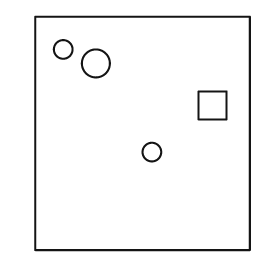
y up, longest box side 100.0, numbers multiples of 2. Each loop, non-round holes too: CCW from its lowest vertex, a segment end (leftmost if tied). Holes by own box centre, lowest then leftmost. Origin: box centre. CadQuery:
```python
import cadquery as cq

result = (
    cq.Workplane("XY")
    .moveTo(-46.0, -50.0)
    .lineTo(46.0, -50.0)
    .lineTo(46.0, 50.0)
    .lineTo(-46.0, 50.0)
    .close()
    .moveTo(4.0, -8.0)
    .circle(4.0)
    .moveTo(24.0, 6.0)
    .lineTo(36.0, 6.0)
    .lineTo(36.0, 18.0)
    .lineTo(24.0, 18.0)
    .close()
    .moveTo(-20.0, 30.0)
    .circle(6.0)
    .moveTo(-34.0, 36.0)
    .circle(4.0)
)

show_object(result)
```